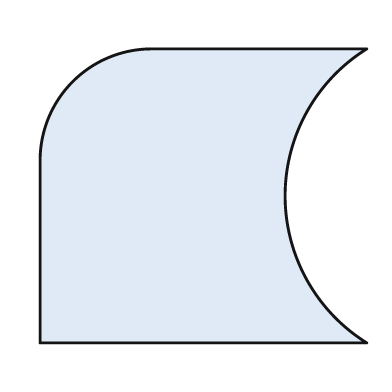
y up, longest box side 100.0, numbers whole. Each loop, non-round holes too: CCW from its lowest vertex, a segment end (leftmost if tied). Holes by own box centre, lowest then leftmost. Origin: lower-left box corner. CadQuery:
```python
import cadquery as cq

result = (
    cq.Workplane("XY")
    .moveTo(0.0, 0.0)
    .lineTo(100.0, 0.0)
    .threePointArc((75.0, 45.0), (100.0, 90.0))
    .lineTo(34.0, 90.0)
    .threePointArc((10.0, 80.0), (0.0, 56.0))
    .close()
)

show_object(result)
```